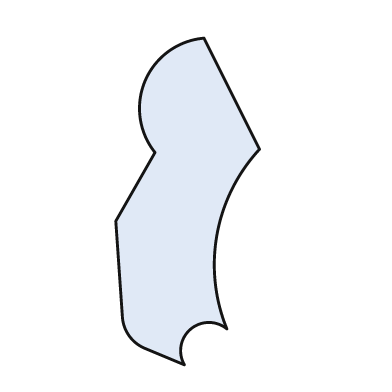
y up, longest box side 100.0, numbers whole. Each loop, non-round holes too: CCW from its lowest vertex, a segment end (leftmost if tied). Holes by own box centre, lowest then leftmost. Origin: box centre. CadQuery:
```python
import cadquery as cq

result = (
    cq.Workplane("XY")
    .moveTo(-1.0, -50.0)
    .threePointArc((1.0, -39.0), (12.0, -39.0))
    .threePointArc((9.0, -10.0), (22.0, 16.0))
    .lineTo(5.0, 50.0)
    .threePointArc((-13.0, 37.0), (-10.0, 15.0))
    .lineTo(-22.0, -6.0)
    .lineTo(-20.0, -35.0)
    .threePointArc((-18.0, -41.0), (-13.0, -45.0))
    .close()
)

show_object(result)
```